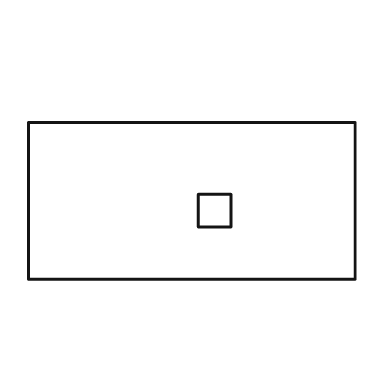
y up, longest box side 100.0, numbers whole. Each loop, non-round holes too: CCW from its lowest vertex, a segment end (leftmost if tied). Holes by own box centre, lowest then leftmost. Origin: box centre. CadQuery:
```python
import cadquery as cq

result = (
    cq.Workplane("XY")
    .moveTo(-50.0, -24.0)
    .lineTo(50.0, -24.0)
    .lineTo(50.0, 24.0)
    .lineTo(-50.0, 24.0)
    .close()
    .moveTo(2.0, -8.0)
    .lineTo(12.0, -8.0)
    .lineTo(12.0, 2.0)
    .lineTo(2.0, 2.0)
    .close()
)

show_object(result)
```